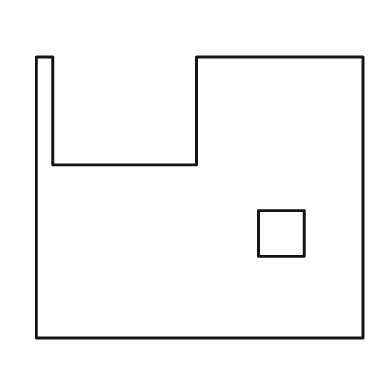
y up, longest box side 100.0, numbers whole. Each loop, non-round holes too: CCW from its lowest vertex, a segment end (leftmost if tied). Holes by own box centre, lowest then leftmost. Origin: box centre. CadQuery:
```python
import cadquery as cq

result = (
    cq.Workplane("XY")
    .moveTo(-50.0, -43.0)
    .lineTo(50.0, -43.0)
    .lineTo(50.0, 43.0)
    .lineTo(-1.0, 43.0)
    .lineTo(-1.0, 10.0)
    .lineTo(-45.0, 10.0)
    .lineTo(-45.0, 43.0)
    .lineTo(-50.0, 43.0)
    .close()
    .moveTo(18.0, -18.0)
    .lineTo(32.0, -18.0)
    .lineTo(32.0, -4.0)
    .lineTo(18.0, -4.0)
    .close()
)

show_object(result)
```